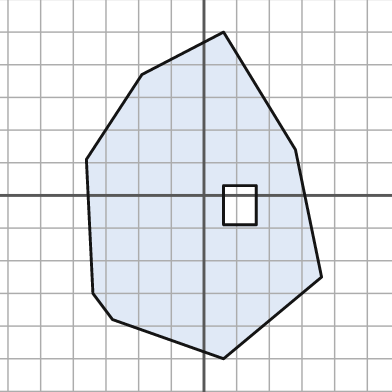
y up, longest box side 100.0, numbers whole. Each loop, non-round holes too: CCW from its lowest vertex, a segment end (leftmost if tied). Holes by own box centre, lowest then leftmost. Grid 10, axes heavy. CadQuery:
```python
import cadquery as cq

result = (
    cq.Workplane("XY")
    .moveTo(6.0, -50.0)
    .lineTo(36.0, -25.0)
    .lineTo(28.0, 14.0)
    .lineTo(6.0, 50.0)
    .lineTo(-19.0, 37.0)
    .lineTo(-36.0, 11.0)
    .lineTo(-34.0, -30.0)
    .lineTo(-28.0, -38.0)
    .close()
    .moveTo(6.0, -9.0)
    .lineTo(16.0, -9.0)
    .lineTo(16.0, 3.0)
    .lineTo(6.0, 3.0)
    .close()
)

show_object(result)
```